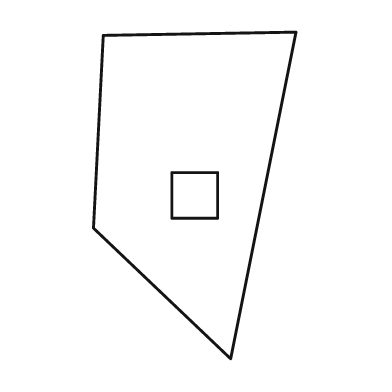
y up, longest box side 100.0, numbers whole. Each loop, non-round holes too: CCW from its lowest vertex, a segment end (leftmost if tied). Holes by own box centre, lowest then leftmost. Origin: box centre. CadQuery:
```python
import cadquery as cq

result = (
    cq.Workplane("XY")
    .moveTo(11.0, -50.0)
    .lineTo(31.0, 50.0)
    .lineTo(-28.0, 49.0)
    .lineTo(-31.0, -10.0)
    .close()
    .moveTo(-7.0, -7.0)
    .lineTo(7.0, -7.0)
    .lineTo(7.0, 7.0)
    .lineTo(-7.0, 7.0)
    .close()
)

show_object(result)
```